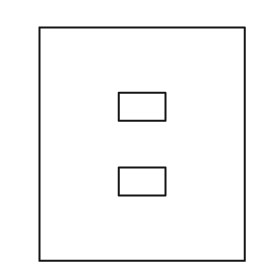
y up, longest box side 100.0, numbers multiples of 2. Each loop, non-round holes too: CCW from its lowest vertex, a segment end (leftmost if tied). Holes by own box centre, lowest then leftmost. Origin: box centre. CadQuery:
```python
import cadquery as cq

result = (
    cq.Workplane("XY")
    .moveTo(-44.0, -50.0)
    .lineTo(44.0, -50.0)
    .lineTo(44.0, 50.0)
    .lineTo(-44.0, 50.0)
    .close()
    .moveTo(-10.0, -22.0)
    .lineTo(10.0, -22.0)
    .lineTo(10.0, -10.0)
    .lineTo(-10.0, -10.0)
    .close()
    .moveTo(-10.0, 10.0)
    .lineTo(10.0, 10.0)
    .lineTo(10.0, 22.0)
    .lineTo(-10.0, 22.0)
    .close()
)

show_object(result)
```